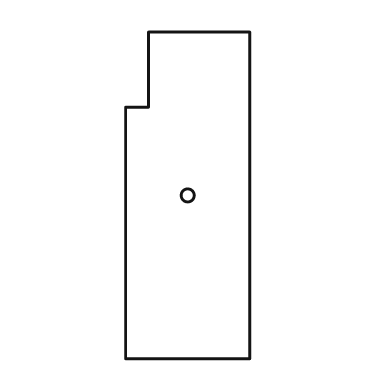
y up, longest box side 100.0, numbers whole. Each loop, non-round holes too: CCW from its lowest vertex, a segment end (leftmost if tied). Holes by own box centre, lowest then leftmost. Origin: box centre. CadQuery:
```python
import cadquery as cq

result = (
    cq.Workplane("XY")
    .moveTo(-19.0, -50.0)
    .lineTo(19.0, -50.0)
    .lineTo(19.0, 50.0)
    .lineTo(-12.0, 50.0)
    .lineTo(-12.0, 27.0)
    .lineTo(-19.0, 27.0)
    .close()
    .moveTo(0.0, 0.0)
    .circle(2.0)
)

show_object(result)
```